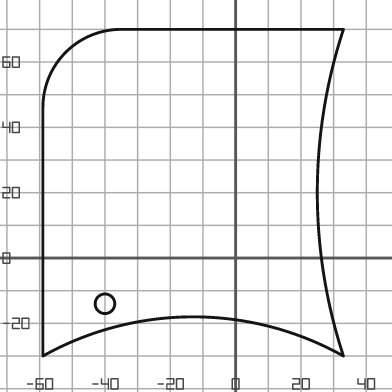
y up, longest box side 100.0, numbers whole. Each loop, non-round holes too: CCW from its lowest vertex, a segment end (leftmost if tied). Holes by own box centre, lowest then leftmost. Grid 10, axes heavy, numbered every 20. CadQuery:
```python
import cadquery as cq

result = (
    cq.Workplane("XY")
    .moveTo(-59.0, -30.0)
    .threePointArc((-13.0, -18.0), (33.0, -30.0))
    .threePointArc((25.0, 20.0), (33.0, 70.0))
    .lineTo(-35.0, 70.0)
    .threePointArc((-52.0, 63.0), (-59.0, 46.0))
    .close()
    .moveTo(-40.0, -14.0)
    .circle(3.0)
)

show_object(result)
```